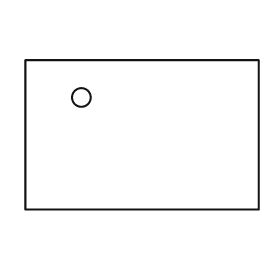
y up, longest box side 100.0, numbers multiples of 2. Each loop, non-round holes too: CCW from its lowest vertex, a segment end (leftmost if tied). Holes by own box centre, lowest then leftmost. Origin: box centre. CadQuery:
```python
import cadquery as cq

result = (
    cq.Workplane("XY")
    .moveTo(-50.0, -32.0)
    .lineTo(50.0, -32.0)
    .lineTo(50.0, 32.0)
    .lineTo(-50.0, 32.0)
    .close()
    .moveTo(-26.0, 16.0)
    .circle(4.0)
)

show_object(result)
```